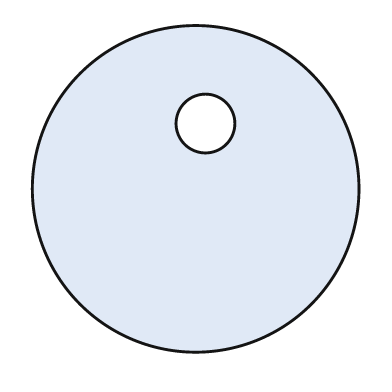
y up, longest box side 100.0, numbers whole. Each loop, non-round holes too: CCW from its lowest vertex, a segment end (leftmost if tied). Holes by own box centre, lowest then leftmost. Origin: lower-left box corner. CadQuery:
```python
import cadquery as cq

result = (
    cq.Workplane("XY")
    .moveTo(50.0, 50.0)
    .circle(50.0)
    .moveTo(53.0, 70.0)
    .circle(9.0)
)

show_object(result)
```